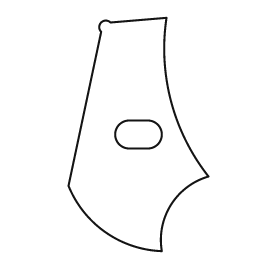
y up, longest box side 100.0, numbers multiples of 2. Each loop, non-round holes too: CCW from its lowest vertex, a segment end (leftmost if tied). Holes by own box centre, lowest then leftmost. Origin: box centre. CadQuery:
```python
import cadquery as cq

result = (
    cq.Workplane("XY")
    .moveTo(10.0, -50.0)
    .threePointArc((14.0, -30.0), (30.0, -18.0))
    .threePointArc((14.0, 14.0), (12.0, 50.0))
    .lineTo(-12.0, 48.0)
    .threePointArc((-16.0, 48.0), (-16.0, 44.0))
    .lineTo(-30.0, -22.0)
    .threePointArc((-14.0, -42.0), (10.0, -50.0))
    .close()
    .moveTo(-4.0, -6.0)
    .lineTo(4.0, -6.0)
    .threePointArc((10.0, 0.0), (4.0, 6.0))
    .lineTo(-4.0, 6.0)
    .threePointArc((-10.0, 0.0), (-4.0, -6.0))
    .close()
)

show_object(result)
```